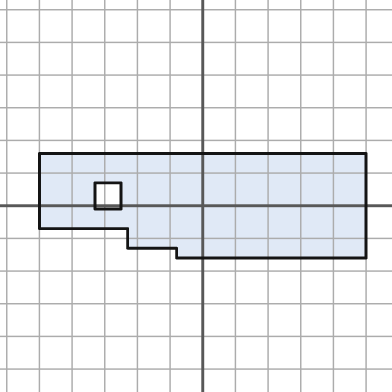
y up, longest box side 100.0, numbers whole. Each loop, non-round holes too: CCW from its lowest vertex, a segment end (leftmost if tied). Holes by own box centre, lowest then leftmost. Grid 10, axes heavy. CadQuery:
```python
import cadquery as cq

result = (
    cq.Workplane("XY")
    .moveTo(-8.0, -16.0)
    .lineTo(50.0, -16.0)
    .lineTo(50.0, 16.0)
    .lineTo(-50.0, 16.0)
    .lineTo(-50.0, -7.0)
    .lineTo(-23.0, -7.0)
    .lineTo(-23.0, -13.0)
    .lineTo(-8.0, -13.0)
    .close()
    .moveTo(-33.0, -1.0)
    .lineTo(-25.0, -1.0)
    .lineTo(-25.0, 7.0)
    .lineTo(-33.0, 7.0)
    .close()
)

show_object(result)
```